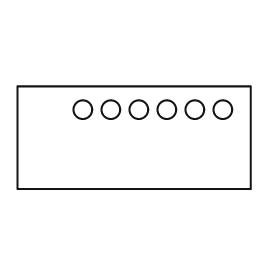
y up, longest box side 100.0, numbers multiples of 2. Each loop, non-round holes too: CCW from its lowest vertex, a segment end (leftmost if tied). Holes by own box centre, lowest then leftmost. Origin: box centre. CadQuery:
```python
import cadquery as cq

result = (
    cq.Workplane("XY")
    .moveTo(-50.0, -22.0)
    .lineTo(50.0, -22.0)
    .lineTo(50.0, 22.0)
    .lineTo(-50.0, 22.0)
    .close()
    .moveTo(-22.0, 12.0)
    .circle(4.0)
    .moveTo(-10.0, 12.0)
    .circle(4.0)
    .moveTo(2.0, 12.0)
    .circle(4.0)
    .moveTo(14.0, 12.0)
    .circle(4.0)
    .moveTo(26.0, 12.0)
    .circle(4.0)
    .moveTo(38.0, 12.0)
    .circle(4.0)
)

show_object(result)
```